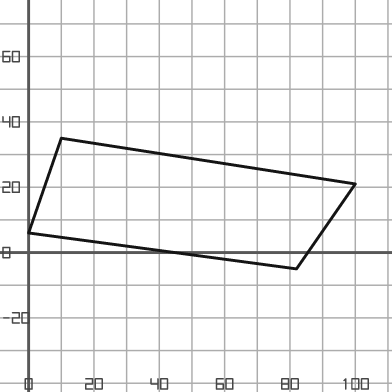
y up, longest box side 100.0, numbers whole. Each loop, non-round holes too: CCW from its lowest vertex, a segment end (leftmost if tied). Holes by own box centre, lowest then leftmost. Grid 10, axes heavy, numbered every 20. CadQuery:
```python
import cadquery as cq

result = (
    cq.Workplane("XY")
    .moveTo(82.0, -5.0)
    .lineTo(100.0, 21.0)
    .lineTo(10.0, 35.0)
    .lineTo(0.0, 6.0)
    .close()
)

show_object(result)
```